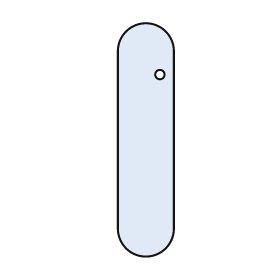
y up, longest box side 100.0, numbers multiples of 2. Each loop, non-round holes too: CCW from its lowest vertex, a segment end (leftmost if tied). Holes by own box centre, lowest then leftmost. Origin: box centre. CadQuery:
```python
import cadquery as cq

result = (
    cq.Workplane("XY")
    .moveTo(-12.0, -38.0)
    .threePointArc((0.0, -50.0), (12.0, -38.0))
    .lineTo(12.0, 38.0)
    .threePointArc((0.0, 50.0), (-12.0, 38.0))
    .close()
    .moveTo(6.0, 28.0)
    .circle(2.0)
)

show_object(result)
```